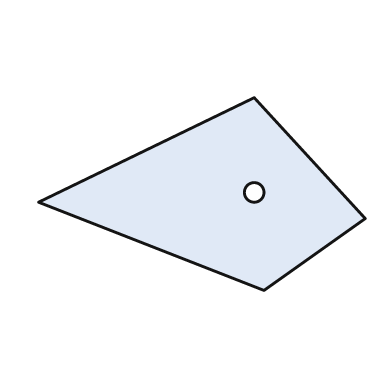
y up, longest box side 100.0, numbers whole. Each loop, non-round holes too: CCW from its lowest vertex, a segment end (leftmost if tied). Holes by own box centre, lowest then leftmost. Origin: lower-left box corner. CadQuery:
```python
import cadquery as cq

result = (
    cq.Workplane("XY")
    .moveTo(69.0, 0.0)
    .lineTo(100.0, 22.0)
    .lineTo(66.0, 59.0)
    .lineTo(0.0, 27.0)
    .close()
    .moveTo(66.0, 30.0)
    .circle(3.0)
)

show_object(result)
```